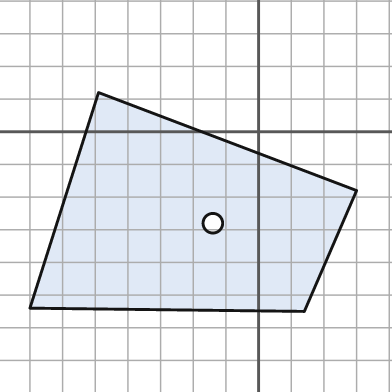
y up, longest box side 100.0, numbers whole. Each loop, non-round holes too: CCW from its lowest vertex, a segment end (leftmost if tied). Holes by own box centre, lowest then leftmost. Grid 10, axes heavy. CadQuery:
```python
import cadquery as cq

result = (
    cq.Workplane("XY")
    .moveTo(14.0, -55.0)
    .lineTo(30.0, -18.0)
    .lineTo(-49.0, 12.0)
    .lineTo(-70.0, -54.0)
    .close()
    .moveTo(-14.0, -28.0)
    .circle(3.0)
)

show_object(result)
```